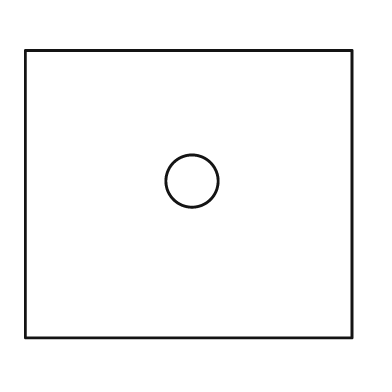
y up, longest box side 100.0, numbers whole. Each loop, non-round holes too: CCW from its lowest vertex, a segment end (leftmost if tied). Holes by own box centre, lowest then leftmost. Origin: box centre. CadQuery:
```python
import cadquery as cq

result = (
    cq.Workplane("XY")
    .moveTo(-50.0, -44.0)
    .lineTo(50.0, -44.0)
    .lineTo(50.0, 44.0)
    .lineTo(-50.0, 44.0)
    .close()
    .moveTo(1.0, 4.0)
    .circle(8.0)
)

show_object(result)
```